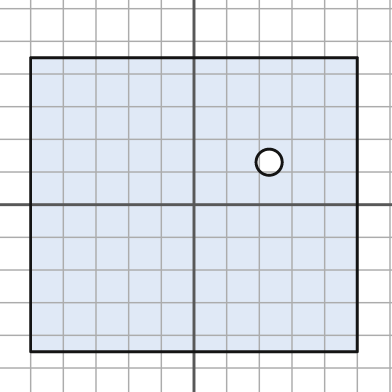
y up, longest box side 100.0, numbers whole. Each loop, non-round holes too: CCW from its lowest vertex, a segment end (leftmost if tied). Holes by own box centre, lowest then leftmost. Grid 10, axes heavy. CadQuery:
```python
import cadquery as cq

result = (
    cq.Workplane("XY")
    .moveTo(-50.0, -45.0)
    .lineTo(50.0, -45.0)
    .lineTo(50.0, 45.0)
    .lineTo(-50.0, 45.0)
    .close()
    .moveTo(23.0, 13.0)
    .circle(4.0)
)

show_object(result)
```